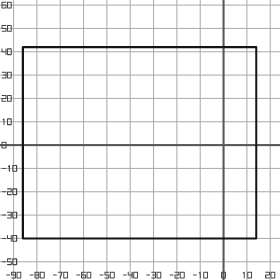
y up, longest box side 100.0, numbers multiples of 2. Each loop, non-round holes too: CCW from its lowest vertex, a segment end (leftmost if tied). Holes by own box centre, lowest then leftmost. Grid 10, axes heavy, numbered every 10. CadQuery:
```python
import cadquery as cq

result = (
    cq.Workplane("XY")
    .moveTo(-86.0, -40.0)
    .lineTo(14.0, -40.0)
    .lineTo(14.0, 42.0)
    .lineTo(-86.0, 42.0)
    .close()
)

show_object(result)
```